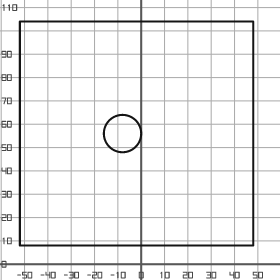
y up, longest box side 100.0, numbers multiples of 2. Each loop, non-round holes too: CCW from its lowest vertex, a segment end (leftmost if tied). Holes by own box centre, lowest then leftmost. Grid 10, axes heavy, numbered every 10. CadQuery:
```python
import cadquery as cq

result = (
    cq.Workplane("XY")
    .moveTo(-52.0, 8.0)
    .lineTo(48.0, 8.0)
    .lineTo(48.0, 104.0)
    .lineTo(-52.0, 104.0)
    .close()
    .moveTo(-8.0, 56.0)
    .circle(8.0)
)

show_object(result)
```